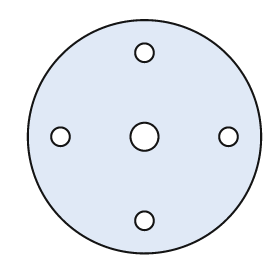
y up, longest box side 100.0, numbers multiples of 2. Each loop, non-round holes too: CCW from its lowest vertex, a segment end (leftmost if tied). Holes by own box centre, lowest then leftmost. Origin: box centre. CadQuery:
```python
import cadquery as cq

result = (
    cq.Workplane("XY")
    .moveTo(0.0, 0.0)
    .circle(50.0)
    .moveTo(0.0, -36.0)
    .circle(4.0)
    .moveTo(-36.0, 0.0)
    .circle(4.0)
    .moveTo(0.0, 0.0)
    .circle(6.0)
    .moveTo(36.0, 0.0)
    .circle(4.0)
    .moveTo(0.0, 36.0)
    .circle(4.0)
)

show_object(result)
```